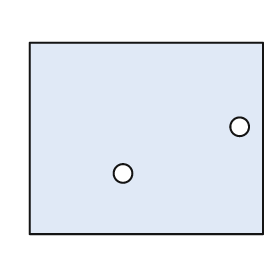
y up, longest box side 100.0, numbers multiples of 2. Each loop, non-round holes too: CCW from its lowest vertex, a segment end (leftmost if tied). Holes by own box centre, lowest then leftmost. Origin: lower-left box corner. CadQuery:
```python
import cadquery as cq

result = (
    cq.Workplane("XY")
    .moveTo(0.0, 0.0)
    .lineTo(100.0, 0.0)
    .lineTo(100.0, 82.0)
    .lineTo(0.0, 82.0)
    .close()
    .moveTo(40.0, 26.0)
    .circle(4.0)
    .moveTo(90.0, 46.0)
    .circle(4.0)
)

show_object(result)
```